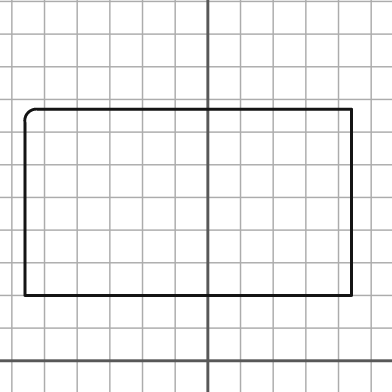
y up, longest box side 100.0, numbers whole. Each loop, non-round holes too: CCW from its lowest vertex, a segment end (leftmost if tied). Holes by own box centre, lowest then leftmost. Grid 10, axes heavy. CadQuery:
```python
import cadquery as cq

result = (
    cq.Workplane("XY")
    .moveTo(-56.0, 20.0)
    .lineTo(44.0, 20.0)
    .lineTo(44.0, 77.0)
    .lineTo(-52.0, 77.0)
    .threePointArc((-55.0, 76.0), (-56.0, 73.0))
    .close()
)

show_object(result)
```